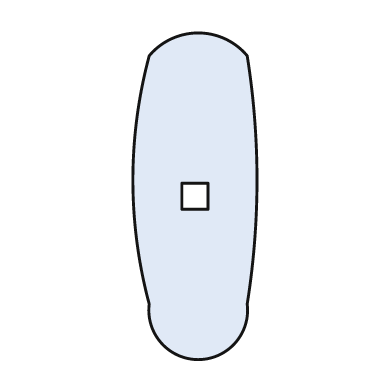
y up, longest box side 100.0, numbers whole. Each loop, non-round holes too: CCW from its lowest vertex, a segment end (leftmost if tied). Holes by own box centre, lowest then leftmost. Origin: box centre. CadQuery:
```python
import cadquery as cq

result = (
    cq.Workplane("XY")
    .moveTo(-14.0, -33.0)
    .threePointArc((1.0, -50.0), (16.0, -33.0))
    .threePointArc((19.0, 5.0), (16.0, 43.0))
    .threePointArc((1.0, 50.0), (-14.0, 43.0))
    .threePointArc((-19.0, 5.0), (-14.0, -33.0))
    .close()
    .moveTo(-4.0, -4.0)
    .lineTo(4.0, -4.0)
    .lineTo(4.0, 4.0)
    .lineTo(-4.0, 4.0)
    .close()
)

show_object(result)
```